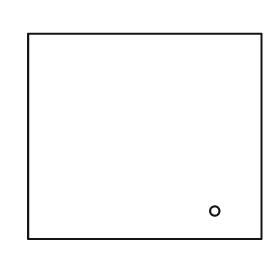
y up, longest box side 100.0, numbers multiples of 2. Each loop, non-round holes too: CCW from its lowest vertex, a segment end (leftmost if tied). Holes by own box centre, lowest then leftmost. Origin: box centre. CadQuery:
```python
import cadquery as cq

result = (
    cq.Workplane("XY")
    .moveTo(-50.0, -44.0)
    .lineTo(50.0, -44.0)
    .lineTo(50.0, 44.0)
    .lineTo(-50.0, 44.0)
    .close()
    .moveTo(30.0, -32.0)
    .circle(2.0)
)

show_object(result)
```